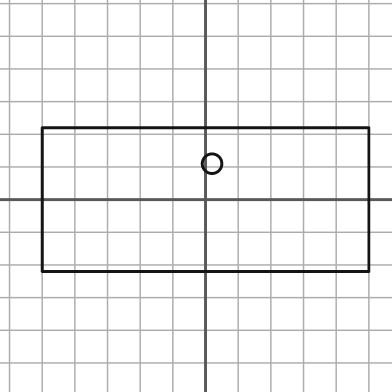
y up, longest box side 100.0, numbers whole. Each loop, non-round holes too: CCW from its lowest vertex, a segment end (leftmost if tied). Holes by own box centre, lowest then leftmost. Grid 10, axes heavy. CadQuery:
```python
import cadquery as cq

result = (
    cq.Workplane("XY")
    .moveTo(-50.0, -22.0)
    .lineTo(50.0, -22.0)
    .lineTo(50.0, 22.0)
    .lineTo(-50.0, 22.0)
    .close()
    .moveTo(2.0, 11.0)
    .circle(3.0)
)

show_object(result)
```